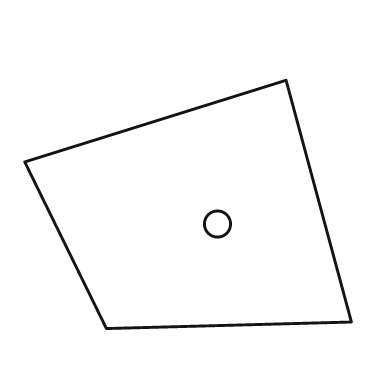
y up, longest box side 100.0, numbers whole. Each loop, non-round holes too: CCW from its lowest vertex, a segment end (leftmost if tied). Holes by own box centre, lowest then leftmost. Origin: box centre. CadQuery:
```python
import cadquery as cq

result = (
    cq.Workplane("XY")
    .moveTo(-25.0, -38.0)
    .lineTo(50.0, -36.0)
    .lineTo(30.0, 38.0)
    .lineTo(-50.0, 13.0)
    .close()
    .moveTo(9.0, -6.0)
    .circle(4.0)
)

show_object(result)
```